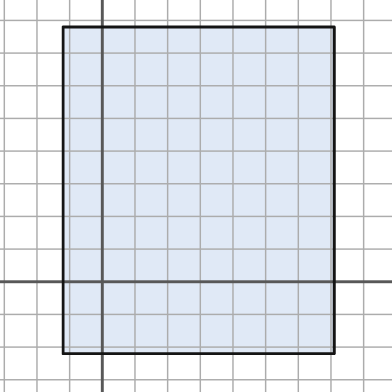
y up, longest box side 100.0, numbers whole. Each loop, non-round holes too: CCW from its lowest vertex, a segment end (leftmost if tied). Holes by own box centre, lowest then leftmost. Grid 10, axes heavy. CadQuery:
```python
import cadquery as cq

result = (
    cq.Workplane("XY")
    .moveTo(-12.0, -22.0)
    .lineTo(71.0, -22.0)
    .lineTo(71.0, 78.0)
    .lineTo(-12.0, 78.0)
    .close()
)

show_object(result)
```